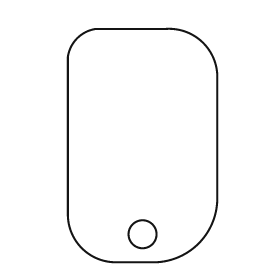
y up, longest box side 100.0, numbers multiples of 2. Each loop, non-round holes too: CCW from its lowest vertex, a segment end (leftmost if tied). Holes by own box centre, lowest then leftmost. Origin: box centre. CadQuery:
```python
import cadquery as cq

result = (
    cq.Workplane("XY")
    .moveTo(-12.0, -50.0)
    .lineTo(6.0, -50.0)
    .threePointArc((24.0, -42.0), (32.0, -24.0))
    .lineTo(32.0, 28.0)
    .threePointArc((26.0, 44.0), (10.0, 50.0))
    .lineTo(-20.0, 50.0)
    .threePointArc((-28.0, 46.0), (-32.0, 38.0))
    .lineTo(-32.0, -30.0)
    .threePointArc((-26.0, -44.0), (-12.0, -50.0))
    .close()
    .moveTo(0.0, -38.0)
    .circle(6.0)
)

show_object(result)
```